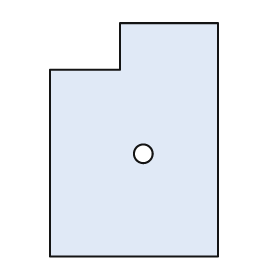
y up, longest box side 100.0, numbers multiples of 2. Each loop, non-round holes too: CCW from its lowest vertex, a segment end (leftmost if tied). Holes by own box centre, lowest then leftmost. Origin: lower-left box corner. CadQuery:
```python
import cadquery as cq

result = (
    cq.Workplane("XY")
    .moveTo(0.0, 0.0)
    .lineTo(72.0, 0.0)
    .lineTo(72.0, 100.0)
    .lineTo(30.0, 100.0)
    .lineTo(30.0, 80.0)
    .lineTo(0.0, 80.0)
    .close()
    .moveTo(40.0, 44.0)
    .circle(4.0)
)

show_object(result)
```